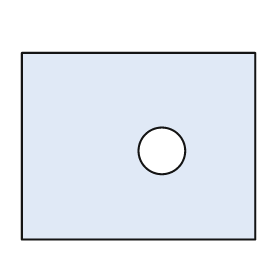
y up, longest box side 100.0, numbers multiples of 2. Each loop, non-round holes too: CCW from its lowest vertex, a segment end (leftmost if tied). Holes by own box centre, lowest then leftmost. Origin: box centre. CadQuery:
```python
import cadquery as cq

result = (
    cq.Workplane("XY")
    .moveTo(-50.0, -40.0)
    .lineTo(50.0, -40.0)
    .lineTo(50.0, 40.0)
    .lineTo(-50.0, 40.0)
    .close()
    .moveTo(10.0, -2.0)
    .circle(10.0)
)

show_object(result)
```